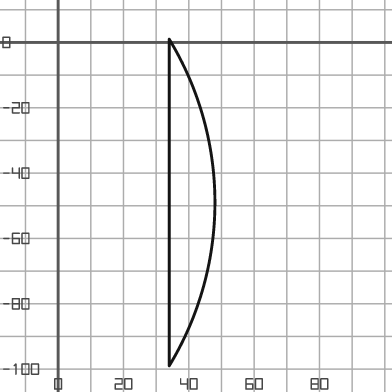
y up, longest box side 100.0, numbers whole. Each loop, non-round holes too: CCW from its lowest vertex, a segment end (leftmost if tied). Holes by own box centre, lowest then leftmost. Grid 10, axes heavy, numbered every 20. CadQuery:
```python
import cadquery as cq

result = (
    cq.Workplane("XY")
    .moveTo(34.0, -99.0)
    .threePointArc((48.0, -49.0), (34.0, 1.0))
    .close()
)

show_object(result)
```